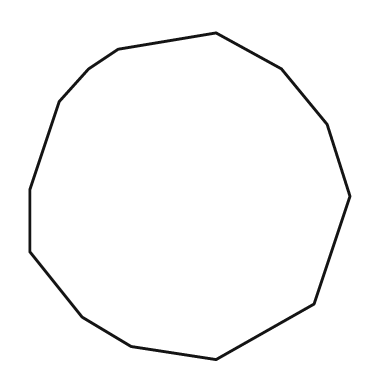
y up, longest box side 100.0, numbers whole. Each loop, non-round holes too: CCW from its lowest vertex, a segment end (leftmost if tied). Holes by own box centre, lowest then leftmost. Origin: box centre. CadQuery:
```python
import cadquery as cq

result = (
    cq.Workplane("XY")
    .moveTo(8.0, -50.0)
    .lineTo(38.0, -33.0)
    .lineTo(49.0, 0.0)
    .lineTo(42.0, 22.0)
    .lineTo(28.0, 39.0)
    .lineTo(8.0, 50.0)
    .lineTo(-22.0, 45.0)
    .lineTo(-31.0, 39.0)
    .lineTo(-40.0, 29.0)
    .lineTo(-49.0, 2.0)
    .lineTo(-49.0, -17.0)
    .lineTo(-33.0, -37.0)
    .lineTo(-18.0, -46.0)
    .close()
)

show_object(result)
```